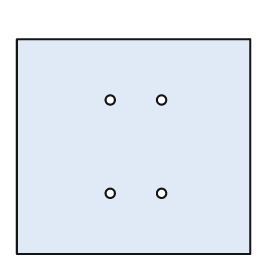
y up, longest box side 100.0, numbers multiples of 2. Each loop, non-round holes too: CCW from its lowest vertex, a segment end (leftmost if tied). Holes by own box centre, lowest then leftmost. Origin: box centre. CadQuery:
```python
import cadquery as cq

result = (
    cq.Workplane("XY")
    .moveTo(-50.0, -46.0)
    .lineTo(50.0, -46.0)
    .lineTo(50.0, 46.0)
    .lineTo(-50.0, 46.0)
    .close()
    .moveTo(-10.0, -20.0)
    .circle(2.0)
    .moveTo(12.0, -20.0)
    .circle(2.0)
    .moveTo(-10.0, 20.0)
    .circle(2.0)
    .moveTo(12.0, 20.0)
    .circle(2.0)
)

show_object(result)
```